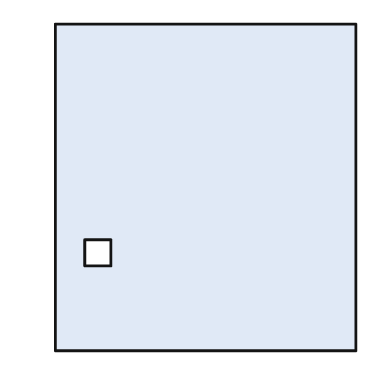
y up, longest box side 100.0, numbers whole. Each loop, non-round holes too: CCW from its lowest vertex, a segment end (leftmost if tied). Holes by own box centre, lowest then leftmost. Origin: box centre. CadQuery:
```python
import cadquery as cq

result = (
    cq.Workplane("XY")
    .moveTo(-46.0, -50.0)
    .lineTo(46.0, -50.0)
    .lineTo(46.0, 50.0)
    .lineTo(-46.0, 50.0)
    .close()
    .moveTo(-37.0, -24.0)
    .lineTo(-29.0, -24.0)
    .lineTo(-29.0, -16.0)
    .lineTo(-37.0, -16.0)
    .close()
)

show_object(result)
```